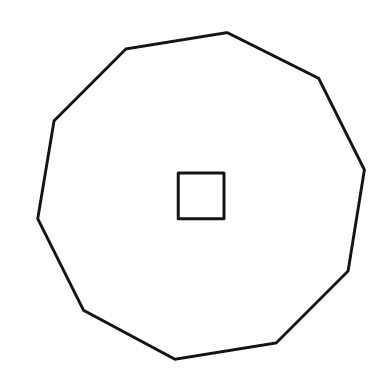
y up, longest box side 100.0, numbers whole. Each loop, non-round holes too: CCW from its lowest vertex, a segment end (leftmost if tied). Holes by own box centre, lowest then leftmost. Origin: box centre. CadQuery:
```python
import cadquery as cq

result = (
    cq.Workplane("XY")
    .moveTo(-8.0, -50.0)
    .lineTo(23.0, -45.0)
    .lineTo(45.0, -23.0)
    .lineTo(50.0, 8.0)
    .lineTo(36.0, 36.0)
    .lineTo(8.0, 50.0)
    .lineTo(-23.0, 45.0)
    .lineTo(-45.0, 23.0)
    .lineTo(-50.0, -7.0)
    .lineTo(-36.0, -35.0)
    .close()
    .moveTo(-7.0, -7.0)
    .lineTo(7.0, -7.0)
    .lineTo(7.0, 7.0)
    .lineTo(-7.0, 7.0)
    .close()
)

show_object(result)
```